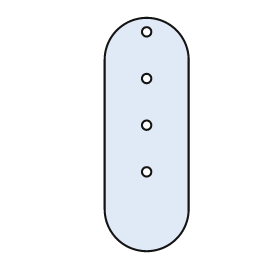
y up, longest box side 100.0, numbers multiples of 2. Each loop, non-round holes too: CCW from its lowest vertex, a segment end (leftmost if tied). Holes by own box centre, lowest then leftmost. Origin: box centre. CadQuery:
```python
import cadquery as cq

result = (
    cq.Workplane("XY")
    .moveTo(-18.0, -32.0)
    .threePointArc((0.0, -50.0), (18.0, -32.0))
    .lineTo(18.0, 32.0)
    .threePointArc((0.0, 50.0), (-18.0, 32.0))
    .close()
    .moveTo(0.0, -16.0)
    .circle(2.0)
    .moveTo(0.0, 4.0)
    .circle(2.0)
    .moveTo(0.0, 24.0)
    .circle(2.0)
    .moveTo(0.0, 44.0)
    .circle(2.0)
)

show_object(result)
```